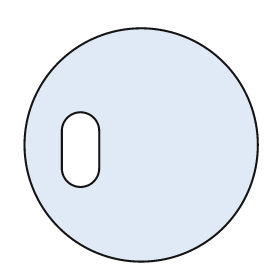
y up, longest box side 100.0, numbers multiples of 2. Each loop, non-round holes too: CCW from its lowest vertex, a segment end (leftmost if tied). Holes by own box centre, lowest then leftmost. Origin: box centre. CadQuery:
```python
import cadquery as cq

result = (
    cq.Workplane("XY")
    .moveTo(0.0, 0.0)
    .circle(50.0)
    .moveTo(-34.0, -10.0)
    .threePointArc((-26.0, -18.0), (-18.0, -10.0))
    .lineTo(-18.0, 6.0)
    .threePointArc((-26.0, 14.0), (-34.0, 6.0))
    .close()
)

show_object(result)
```